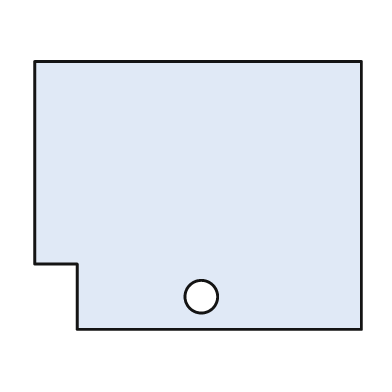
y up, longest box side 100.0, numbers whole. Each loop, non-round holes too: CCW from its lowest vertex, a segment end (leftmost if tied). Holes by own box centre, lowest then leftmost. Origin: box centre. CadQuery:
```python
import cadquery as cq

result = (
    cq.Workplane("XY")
    .moveTo(-37.0, -41.0)
    .lineTo(50.0, -41.0)
    .lineTo(50.0, 41.0)
    .lineTo(-50.0, 41.0)
    .lineTo(-50.0, -21.0)
    .lineTo(-37.0, -21.0)
    .close()
    .moveTo(1.0, -31.0)
    .circle(5.0)
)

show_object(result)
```